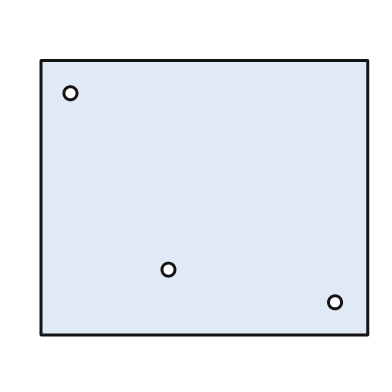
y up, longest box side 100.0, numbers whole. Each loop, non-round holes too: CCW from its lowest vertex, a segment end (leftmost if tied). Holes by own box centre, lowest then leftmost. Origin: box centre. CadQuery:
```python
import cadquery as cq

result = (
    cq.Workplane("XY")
    .moveTo(-50.0, -42.0)
    .lineTo(50.0, -42.0)
    .lineTo(50.0, 42.0)
    .lineTo(-50.0, 42.0)
    .close()
    .moveTo(40.0, -32.0)
    .circle(2.0)
    .moveTo(-11.0, -22.0)
    .circle(2.0)
    .moveTo(-41.0, 32.0)
    .circle(2.0)
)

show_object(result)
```